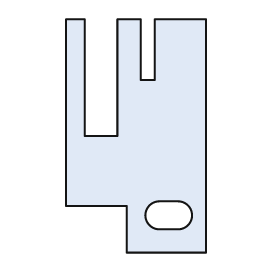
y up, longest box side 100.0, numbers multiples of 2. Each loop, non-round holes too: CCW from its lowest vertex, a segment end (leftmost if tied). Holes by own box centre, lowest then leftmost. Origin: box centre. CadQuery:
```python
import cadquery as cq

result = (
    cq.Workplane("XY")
    .moveTo(-4.0, -50.0)
    .lineTo(30.0, -50.0)
    .lineTo(30.0, 50.0)
    .lineTo(8.0, 50.0)
    .lineTo(8.0, 24.0)
    .lineTo(2.0, 24.0)
    .lineTo(2.0, 50.0)
    .lineTo(-8.0, 50.0)
    .lineTo(-8.0, 0.0)
    .lineTo(-22.0, 0.0)
    .lineTo(-22.0, 50.0)
    .lineTo(-30.0, 50.0)
    .lineTo(-30.0, -30.0)
    .lineTo(-4.0, -30.0)
    .close()
    .moveTo(10.0, -40.0)
    .lineTo(18.0, -40.0)
    .threePointArc((24.0, -34.0), (18.0, -28.0))
    .lineTo(10.0, -28.0)
    .threePointArc((4.0, -34.0), (10.0, -40.0))
    .close()
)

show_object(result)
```